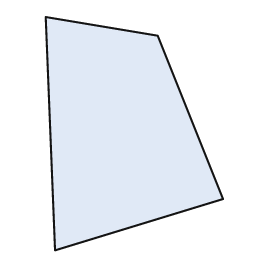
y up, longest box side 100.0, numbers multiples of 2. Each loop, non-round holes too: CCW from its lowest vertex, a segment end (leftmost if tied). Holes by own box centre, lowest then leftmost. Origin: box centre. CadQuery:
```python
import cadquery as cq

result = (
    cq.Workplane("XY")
    .moveTo(-34.0, -50.0)
    .lineTo(38.0, -28.0)
    .lineTo(10.0, 42.0)
    .lineTo(-38.0, 50.0)
    .close()
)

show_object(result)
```